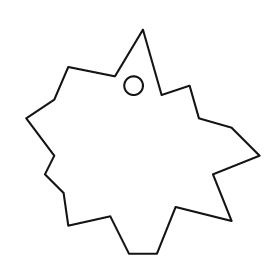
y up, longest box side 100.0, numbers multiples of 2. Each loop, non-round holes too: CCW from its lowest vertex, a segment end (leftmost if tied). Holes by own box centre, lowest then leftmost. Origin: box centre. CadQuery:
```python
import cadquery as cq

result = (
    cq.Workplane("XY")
    .moveTo(-6.0, -48.0)
    .lineTo(6.0, -48.0)
    .lineTo(14.0, -28.0)
    .lineTo(38.0, -34.0)
    .lineTo(30.0, -14.0)
    .lineTo(50.0, -6.0)
    .lineTo(38.0, 6.0)
    .lineTo(24.0, 10.0)
    .lineTo(20.0, 24.0)
    .lineTo(8.0, 20.0)
    .lineTo(0.0, 48.0)
    .lineTo(-12.0, 28.0)
    .lineTo(-32.0, 32.0)
    .lineTo(-38.0, 18.0)
    .lineTo(-50.0, 10.0)
    .lineTo(-38.0, -6.0)
    .lineTo(-42.0, -14.0)
    .lineTo(-34.0, -22.0)
    .lineTo(-32.0, -36.0)
    .lineTo(-14.0, -32.0)
    .close()
    .moveTo(-4.0, 24.0)
    .circle(4.0)
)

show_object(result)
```